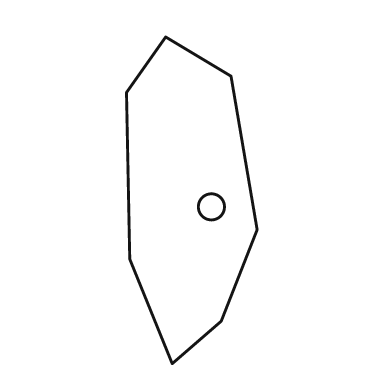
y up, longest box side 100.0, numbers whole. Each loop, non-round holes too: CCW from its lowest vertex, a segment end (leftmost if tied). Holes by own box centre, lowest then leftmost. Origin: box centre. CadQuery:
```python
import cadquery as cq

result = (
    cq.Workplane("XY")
    .moveTo(-6.0, -50.0)
    .lineTo(9.0, -37.0)
    .lineTo(20.0, -9.0)
    .lineTo(12.0, 38.0)
    .lineTo(-8.0, 50.0)
    .lineTo(-20.0, 33.0)
    .lineTo(-19.0, -18.0)
    .close()
    .moveTo(6.0, -2.0)
    .circle(4.0)
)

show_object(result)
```